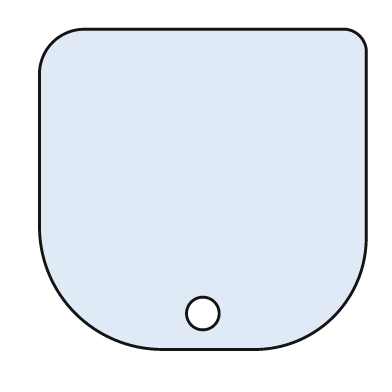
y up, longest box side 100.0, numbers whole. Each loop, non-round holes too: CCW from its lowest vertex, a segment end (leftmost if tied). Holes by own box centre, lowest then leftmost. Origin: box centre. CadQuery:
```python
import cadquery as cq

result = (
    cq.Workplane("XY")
    .moveTo(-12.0, -49.0)
    .lineTo(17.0, -49.0)
    .threePointArc((40.0, -39.0), (50.0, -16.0))
    .lineTo(50.0, 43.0)
    .threePointArc((48.0, 47.0), (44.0, 49.0))
    .lineTo(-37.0, 49.0)
    .threePointArc((-46.0, 45.0), (-50.0, 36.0))
    .lineTo(-50.0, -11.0)
    .threePointArc((-39.0, -38.0), (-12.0, -49.0))
    .close()
    .moveTo(0.0, -38.0)
    .circle(5.0)
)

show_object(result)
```